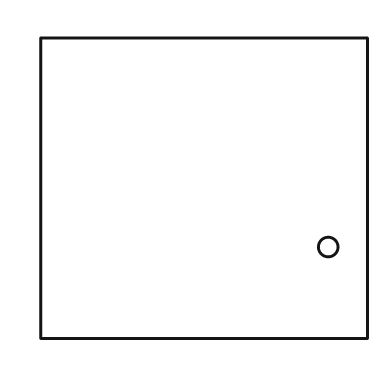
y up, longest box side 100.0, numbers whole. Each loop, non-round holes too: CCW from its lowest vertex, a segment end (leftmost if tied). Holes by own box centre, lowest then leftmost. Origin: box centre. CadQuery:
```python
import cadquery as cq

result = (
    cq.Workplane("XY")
    .moveTo(-50.0, -46.0)
    .lineTo(50.0, -46.0)
    .lineTo(50.0, 46.0)
    .lineTo(-50.0, 46.0)
    .close()
    .moveTo(38.0, -18.0)
    .circle(3.0)
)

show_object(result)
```